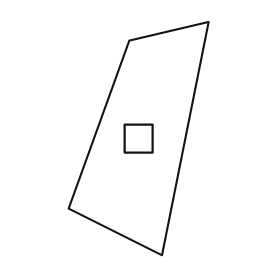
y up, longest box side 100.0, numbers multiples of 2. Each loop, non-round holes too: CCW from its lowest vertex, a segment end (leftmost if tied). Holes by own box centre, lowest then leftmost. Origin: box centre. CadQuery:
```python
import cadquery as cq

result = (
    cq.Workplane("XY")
    .moveTo(10.0, -50.0)
    .lineTo(30.0, 50.0)
    .lineTo(-4.0, 42.0)
    .lineTo(-30.0, -30.0)
    .close()
    .moveTo(-6.0, -6.0)
    .lineTo(6.0, -6.0)
    .lineTo(6.0, 6.0)
    .lineTo(-6.0, 6.0)
    .close()
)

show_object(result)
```